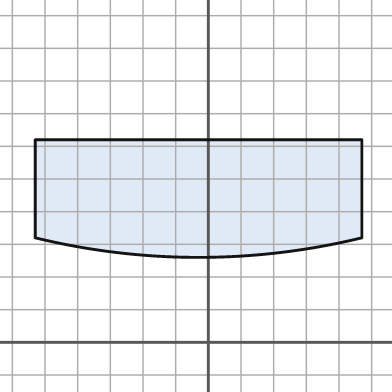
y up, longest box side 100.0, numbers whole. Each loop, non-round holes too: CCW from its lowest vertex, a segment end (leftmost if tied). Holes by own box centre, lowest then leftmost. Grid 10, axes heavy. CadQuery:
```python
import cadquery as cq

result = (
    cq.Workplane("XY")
    .moveTo(-53.0, 32.0)
    .threePointArc((-3.0, 26.0), (47.0, 32.0))
    .lineTo(47.0, 62.0)
    .lineTo(-53.0, 62.0)
    .close()
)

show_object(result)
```